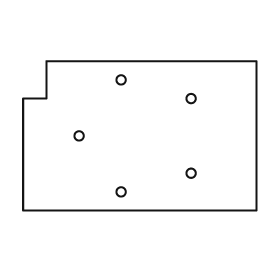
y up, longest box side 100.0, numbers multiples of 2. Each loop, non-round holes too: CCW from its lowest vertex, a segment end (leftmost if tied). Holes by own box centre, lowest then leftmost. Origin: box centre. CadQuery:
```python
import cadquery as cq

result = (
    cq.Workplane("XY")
    .moveTo(-50.0, -32.0)
    .lineTo(50.0, -32.0)
    .lineTo(50.0, 32.0)
    .lineTo(-40.0, 32.0)
    .lineTo(-40.0, 16.0)
    .lineTo(-50.0, 16.0)
    .close()
    .moveTo(-8.0, -24.0)
    .circle(2.0)
    .moveTo(22.0, -16.0)
    .circle(2.0)
    .moveTo(-26.0, 0.0)
    .circle(2.0)
    .moveTo(22.0, 16.0)
    .circle(2.0)
    .moveTo(-8.0, 24.0)
    .circle(2.0)
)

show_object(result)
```